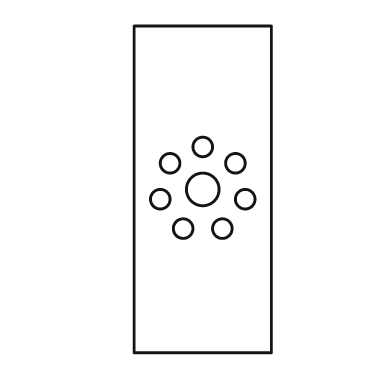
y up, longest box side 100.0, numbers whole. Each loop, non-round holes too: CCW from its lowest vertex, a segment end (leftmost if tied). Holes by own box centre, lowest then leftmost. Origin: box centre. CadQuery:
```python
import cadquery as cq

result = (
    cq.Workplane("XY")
    .moveTo(-21.0, -50.0)
    .lineTo(21.0, -50.0)
    .lineTo(21.0, 50.0)
    .lineTo(-21.0, 50.0)
    .close()
    .moveTo(-6.0, -12.0)
    .circle(3.0)
    .moveTo(6.0, -12.0)
    .circle(3.0)
    .moveTo(-13.0, -3.0)
    .circle(3.0)
    .moveTo(13.0, -3.0)
    .circle(3.0)
    .moveTo(0.0, 0.0)
    .circle(5.0)
    .moveTo(-10.0, 8.0)
    .circle(3.0)
    .moveTo(10.0, 8.0)
    .circle(3.0)
    .moveTo(0.0, 13.0)
    .circle(3.0)
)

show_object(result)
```